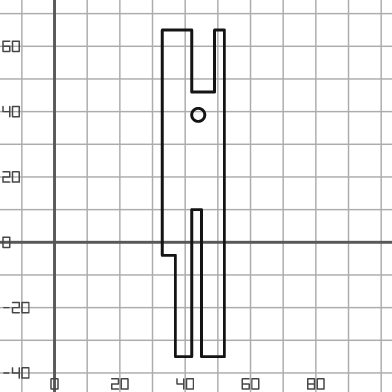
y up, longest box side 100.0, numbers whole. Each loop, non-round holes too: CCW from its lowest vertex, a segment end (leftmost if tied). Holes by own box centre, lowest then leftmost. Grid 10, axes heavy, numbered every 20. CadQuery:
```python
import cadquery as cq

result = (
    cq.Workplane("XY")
    .moveTo(37.0, -35.0)
    .lineTo(42.0, -35.0)
    .lineTo(42.0, 10.0)
    .lineTo(45.0, 10.0)
    .lineTo(45.0, -35.0)
    .lineTo(52.0, -35.0)
    .lineTo(52.0, 65.0)
    .lineTo(49.0, 65.0)
    .lineTo(49.0, 46.0)
    .lineTo(42.0, 46.0)
    .lineTo(42.0, 65.0)
    .lineTo(33.0, 65.0)
    .lineTo(33.0, -4.0)
    .lineTo(37.0, -4.0)
    .close()
    .moveTo(44.0, 39.0)
    .circle(2.0)
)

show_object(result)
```